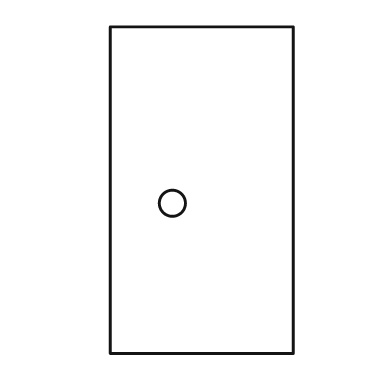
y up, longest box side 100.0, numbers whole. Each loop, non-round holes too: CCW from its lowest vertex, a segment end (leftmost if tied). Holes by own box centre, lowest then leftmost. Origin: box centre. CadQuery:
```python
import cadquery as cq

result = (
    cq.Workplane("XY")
    .moveTo(-28.0, -50.0)
    .lineTo(28.0, -50.0)
    .lineTo(28.0, 50.0)
    .lineTo(-28.0, 50.0)
    .close()
    .moveTo(-9.0, -4.0)
    .circle(4.0)
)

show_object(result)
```